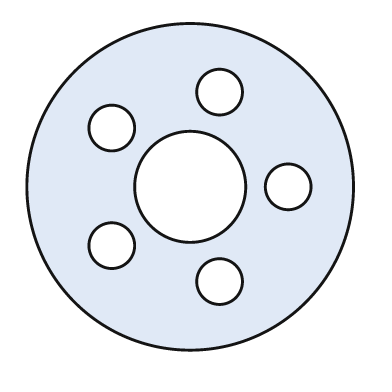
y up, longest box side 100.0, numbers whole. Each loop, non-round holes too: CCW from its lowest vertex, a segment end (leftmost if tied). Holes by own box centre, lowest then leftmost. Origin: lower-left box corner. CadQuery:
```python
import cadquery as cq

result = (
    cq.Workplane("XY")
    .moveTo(50.0, 50.0)
    .circle(50.0)
    .moveTo(59.0, 21.0)
    .circle(7.0)
    .moveTo(26.0, 32.0)
    .circle(7.0)
    .moveTo(50.0, 50.0)
    .circle(17.0)
    .moveTo(80.0, 50.0)
    .circle(7.0)
    .moveTo(26.0, 68.0)
    .circle(7.0)
    .moveTo(59.0, 79.0)
    .circle(7.0)
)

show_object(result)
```